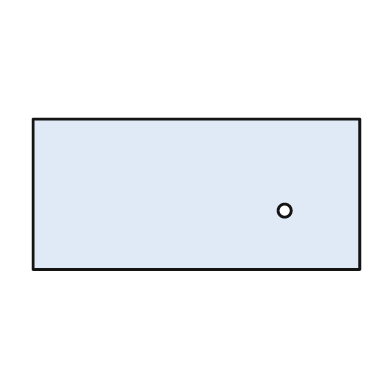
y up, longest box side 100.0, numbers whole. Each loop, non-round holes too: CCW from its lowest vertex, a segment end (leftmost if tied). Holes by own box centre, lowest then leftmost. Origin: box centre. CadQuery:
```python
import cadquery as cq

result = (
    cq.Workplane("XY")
    .moveTo(-50.0, -23.0)
    .lineTo(50.0, -23.0)
    .lineTo(50.0, 23.0)
    .lineTo(-50.0, 23.0)
    .close()
    .moveTo(27.0, -5.0)
    .circle(2.0)
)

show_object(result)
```